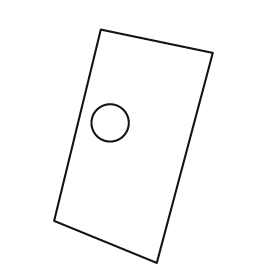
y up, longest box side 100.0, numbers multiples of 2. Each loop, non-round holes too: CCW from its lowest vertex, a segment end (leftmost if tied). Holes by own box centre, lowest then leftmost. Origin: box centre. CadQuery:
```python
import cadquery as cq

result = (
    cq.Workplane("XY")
    .moveTo(10.0, -50.0)
    .lineTo(34.0, 40.0)
    .lineTo(-14.0, 50.0)
    .lineTo(-34.0, -32.0)
    .close()
    .moveTo(-10.0, 10.0)
    .circle(8.0)
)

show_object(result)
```